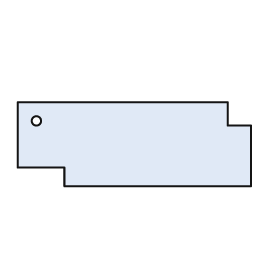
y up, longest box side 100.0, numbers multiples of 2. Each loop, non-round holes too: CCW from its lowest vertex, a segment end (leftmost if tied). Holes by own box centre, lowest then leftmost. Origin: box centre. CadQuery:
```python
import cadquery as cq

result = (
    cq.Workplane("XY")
    .moveTo(-30.0, -18.0)
    .lineTo(50.0, -18.0)
    .lineTo(50.0, 8.0)
    .lineTo(40.0, 8.0)
    .lineTo(40.0, 18.0)
    .lineTo(-50.0, 18.0)
    .lineTo(-50.0, -10.0)
    .lineTo(-30.0, -10.0)
    .close()
    .moveTo(-42.0, 10.0)
    .circle(2.0)
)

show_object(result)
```